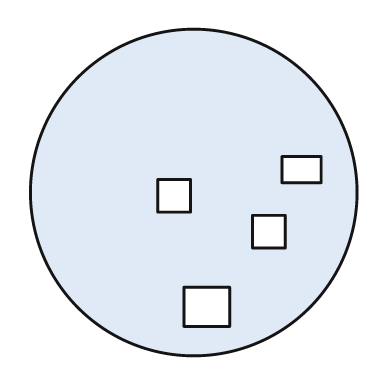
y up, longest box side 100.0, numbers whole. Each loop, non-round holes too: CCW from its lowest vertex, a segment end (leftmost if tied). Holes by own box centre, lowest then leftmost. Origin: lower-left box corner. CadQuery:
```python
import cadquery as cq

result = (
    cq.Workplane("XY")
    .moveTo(50.0, 50.0)
    .circle(50.0)
    .moveTo(47.0, 9.0)
    .lineTo(61.0, 9.0)
    .lineTo(61.0, 21.0)
    .lineTo(47.0, 21.0)
    .close()
    .moveTo(68.0, 33.0)
    .lineTo(78.0, 33.0)
    .lineTo(78.0, 43.0)
    .lineTo(68.0, 43.0)
    .close()
    .moveTo(39.0, 44.0)
    .lineTo(49.0, 44.0)
    .lineTo(49.0, 54.0)
    .lineTo(39.0, 54.0)
    .close()
    .moveTo(77.0, 53.0)
    .lineTo(89.0, 53.0)
    .lineTo(89.0, 61.0)
    .lineTo(77.0, 61.0)
    .close()
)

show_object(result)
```